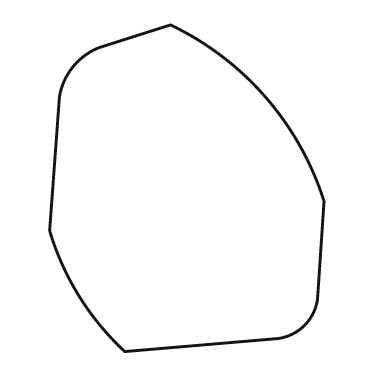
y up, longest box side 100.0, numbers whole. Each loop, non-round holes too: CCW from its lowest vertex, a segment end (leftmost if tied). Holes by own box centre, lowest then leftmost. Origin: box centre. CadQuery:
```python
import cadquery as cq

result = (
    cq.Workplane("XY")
    .moveTo(-19.0, -50.0)
    .lineTo(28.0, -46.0)
    .threePointArc((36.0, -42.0), (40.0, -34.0))
    .lineTo(42.0, -4.0)
    .threePointArc((24.0, 28.0), (-5.0, 50.0))
    .lineTo(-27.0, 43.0)
    .threePointArc((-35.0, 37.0), (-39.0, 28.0))
    .lineTo(-42.0, -13.0)
    .threePointArc((-33.0, -33.0), (-19.0, -50.0))
    .close()
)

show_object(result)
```